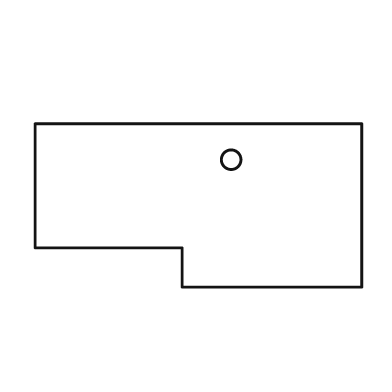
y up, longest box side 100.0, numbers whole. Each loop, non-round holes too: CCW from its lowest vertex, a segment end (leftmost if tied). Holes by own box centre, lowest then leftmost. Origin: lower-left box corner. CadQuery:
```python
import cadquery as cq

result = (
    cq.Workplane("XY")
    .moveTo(45.0, 0.0)
    .lineTo(100.0, 0.0)
    .lineTo(100.0, 50.0)
    .lineTo(0.0, 50.0)
    .lineTo(0.0, 12.0)
    .lineTo(45.0, 12.0)
    .close()
    .moveTo(60.0, 39.0)
    .circle(3.0)
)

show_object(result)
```